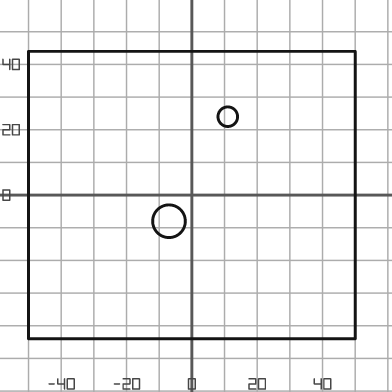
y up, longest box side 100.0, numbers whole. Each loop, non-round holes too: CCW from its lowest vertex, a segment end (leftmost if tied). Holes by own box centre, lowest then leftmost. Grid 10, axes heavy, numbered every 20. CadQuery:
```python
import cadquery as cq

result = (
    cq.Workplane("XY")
    .moveTo(-50.0, -44.0)
    .lineTo(50.0, -44.0)
    .lineTo(50.0, 44.0)
    .lineTo(-50.0, 44.0)
    .close()
    .moveTo(-7.0, -8.0)
    .circle(5.0)
    .moveTo(11.0, 24.0)
    .circle(3.0)
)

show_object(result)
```